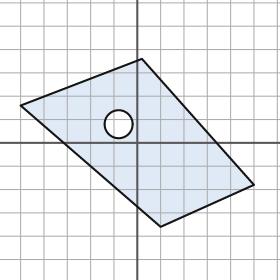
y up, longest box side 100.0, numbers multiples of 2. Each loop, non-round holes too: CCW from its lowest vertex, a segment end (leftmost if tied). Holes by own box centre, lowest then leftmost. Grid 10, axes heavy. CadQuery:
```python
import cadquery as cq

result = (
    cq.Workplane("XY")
    .moveTo(10.0, -36.0)
    .lineTo(50.0, -18.0)
    .lineTo(2.0, 36.0)
    .lineTo(-50.0, 16.0)
    .close()
    .moveTo(-8.0, 8.0)
    .circle(6.0)
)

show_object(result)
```